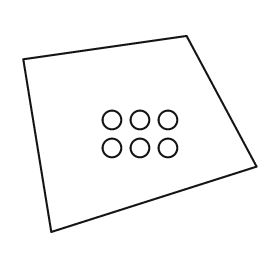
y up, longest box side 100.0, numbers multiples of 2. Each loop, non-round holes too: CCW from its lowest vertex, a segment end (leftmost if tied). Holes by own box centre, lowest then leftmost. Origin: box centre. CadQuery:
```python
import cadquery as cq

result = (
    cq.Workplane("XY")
    .moveTo(-38.0, -42.0)
    .lineTo(50.0, -14.0)
    .lineTo(20.0, 42.0)
    .lineTo(-50.0, 32.0)
    .close()
    .moveTo(-12.0, -6.0)
    .circle(4.0)
    .moveTo(0.0, -6.0)
    .circle(4.0)
    .moveTo(12.0, -6.0)
    .circle(4.0)
    .moveTo(-12.0, 6.0)
    .circle(4.0)
    .moveTo(0.0, 6.0)
    .circle(4.0)
    .moveTo(12.0, 6.0)
    .circle(4.0)
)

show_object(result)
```